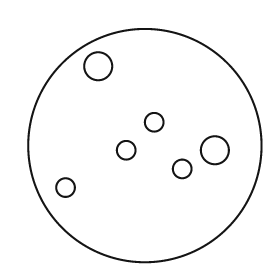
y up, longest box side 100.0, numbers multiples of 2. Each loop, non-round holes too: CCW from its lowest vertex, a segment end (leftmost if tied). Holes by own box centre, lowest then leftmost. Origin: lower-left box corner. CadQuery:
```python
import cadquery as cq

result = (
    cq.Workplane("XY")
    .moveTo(50.0, 50.0)
    .circle(50.0)
    .moveTo(16.0, 32.0)
    .circle(4.0)
    .moveTo(66.0, 40.0)
    .circle(4.0)
    .moveTo(42.0, 48.0)
    .circle(4.0)
    .moveTo(80.0, 48.0)
    .circle(6.0)
    .moveTo(54.0, 60.0)
    .circle(4.0)
    .moveTo(30.0, 84.0)
    .circle(6.0)
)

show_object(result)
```